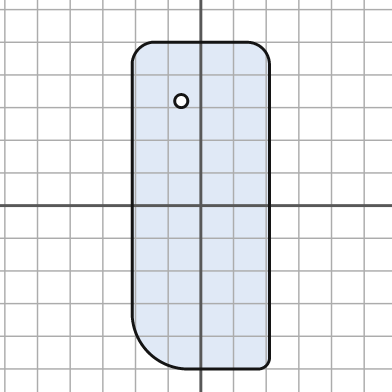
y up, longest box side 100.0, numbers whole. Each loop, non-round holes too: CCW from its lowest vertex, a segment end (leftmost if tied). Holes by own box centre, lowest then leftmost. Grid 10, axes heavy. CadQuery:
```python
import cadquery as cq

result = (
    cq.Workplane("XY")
    .moveTo(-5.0, -50.0)
    .lineTo(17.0, -50.0)
    .threePointArc((20.0, -49.0), (21.0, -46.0))
    .lineTo(21.0, 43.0)
    .threePointArc((19.0, 48.0), (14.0, 50.0))
    .lineTo(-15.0, 50.0)
    .threePointArc((-19.0, 48.0), (-21.0, 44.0))
    .lineTo(-21.0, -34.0)
    .threePointArc((-16.0, -45.0), (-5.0, -50.0))
    .close()
    .moveTo(-6.0, 32.0)
    .circle(2.0)
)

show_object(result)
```